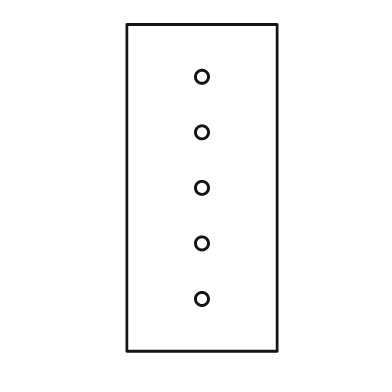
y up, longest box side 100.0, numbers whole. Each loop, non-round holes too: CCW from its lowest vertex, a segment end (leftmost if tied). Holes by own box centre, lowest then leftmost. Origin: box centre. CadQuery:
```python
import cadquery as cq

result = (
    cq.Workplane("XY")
    .moveTo(-23.0, -50.0)
    .lineTo(23.0, -50.0)
    .lineTo(23.0, 50.0)
    .lineTo(-23.0, 50.0)
    .close()
    .moveTo(0.0, -34.0)
    .circle(2.0)
    .moveTo(0.0, -17.0)
    .circle(2.0)
    .moveTo(0.0, 0.0)
    .circle(2.0)
    .moveTo(0.0, 17.0)
    .circle(2.0)
    .moveTo(0.0, 34.0)
    .circle(2.0)
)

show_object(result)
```